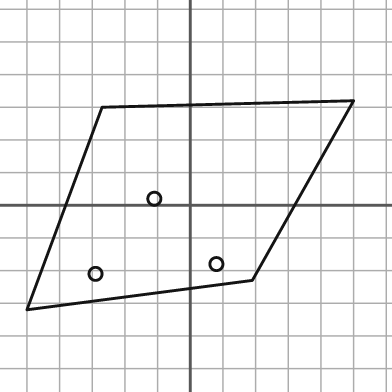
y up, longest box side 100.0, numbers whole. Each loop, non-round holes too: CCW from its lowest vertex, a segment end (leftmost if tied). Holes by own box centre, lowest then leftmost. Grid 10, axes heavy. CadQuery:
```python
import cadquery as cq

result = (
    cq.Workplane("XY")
    .moveTo(-50.0, -32.0)
    .lineTo(19.0, -23.0)
    .lineTo(50.0, 32.0)
    .lineTo(-27.0, 30.0)
    .close()
    .moveTo(-29.0, -21.0)
    .circle(2.0)
    .moveTo(8.0, -18.0)
    .circle(2.0)
    .moveTo(-11.0, 2.0)
    .circle(2.0)
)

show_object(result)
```